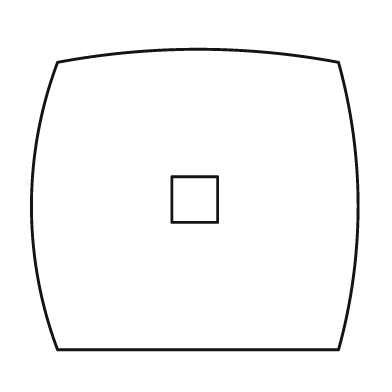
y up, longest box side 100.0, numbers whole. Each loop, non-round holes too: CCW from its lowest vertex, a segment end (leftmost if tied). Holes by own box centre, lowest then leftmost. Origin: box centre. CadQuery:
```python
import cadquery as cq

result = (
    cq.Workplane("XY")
    .moveTo(-42.0, -46.0)
    .lineTo(44.0, -46.0)
    .threePointArc((50.0, -2.0), (44.0, 42.0))
    .threePointArc((1.0, 46.0), (-42.0, 42.0))
    .threePointArc((-50.0, -2.0), (-42.0, -46.0))
    .close()
    .moveTo(-7.0, -7.0)
    .lineTo(7.0, -7.0)
    .lineTo(7.0, 7.0)
    .lineTo(-7.0, 7.0)
    .close()
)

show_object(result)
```